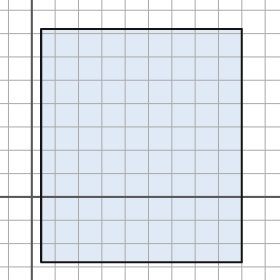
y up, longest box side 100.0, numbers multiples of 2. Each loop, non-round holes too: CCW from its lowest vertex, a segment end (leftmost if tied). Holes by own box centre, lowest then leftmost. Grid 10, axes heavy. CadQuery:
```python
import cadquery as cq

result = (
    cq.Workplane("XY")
    .moveTo(4.0, -28.0)
    .lineTo(90.0, -28.0)
    .lineTo(90.0, 72.0)
    .lineTo(4.0, 72.0)
    .close()
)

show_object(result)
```